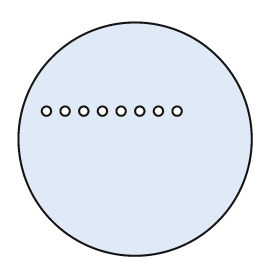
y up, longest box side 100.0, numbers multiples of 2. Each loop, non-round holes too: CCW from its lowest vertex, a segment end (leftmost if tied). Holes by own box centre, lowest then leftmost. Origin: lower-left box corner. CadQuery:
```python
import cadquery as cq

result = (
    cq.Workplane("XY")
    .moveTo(50.0, 50.0)
    .circle(50.0)
    .moveTo(12.0, 62.0)
    .circle(2.0)
    .moveTo(20.0, 62.0)
    .circle(2.0)
    .moveTo(28.0, 62.0)
    .circle(2.0)
    .moveTo(36.0, 62.0)
    .circle(2.0)
    .moveTo(44.0, 62.0)
    .circle(2.0)
    .moveTo(52.0, 62.0)
    .circle(2.0)
    .moveTo(60.0, 62.0)
    .circle(2.0)
    .moveTo(68.0, 62.0)
    .circle(2.0)
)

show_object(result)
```